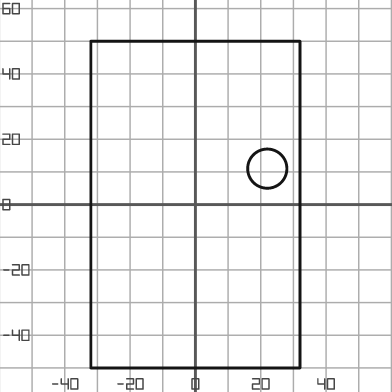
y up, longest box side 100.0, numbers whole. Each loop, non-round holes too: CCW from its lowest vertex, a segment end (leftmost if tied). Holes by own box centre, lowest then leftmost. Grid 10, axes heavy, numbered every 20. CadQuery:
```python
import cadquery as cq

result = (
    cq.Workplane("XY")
    .moveTo(-32.0, -50.0)
    .lineTo(32.0, -50.0)
    .lineTo(32.0, 50.0)
    .lineTo(-32.0, 50.0)
    .close()
    .moveTo(22.0, 11.0)
    .circle(6.0)
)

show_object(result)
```